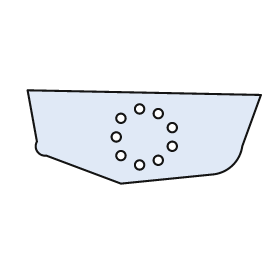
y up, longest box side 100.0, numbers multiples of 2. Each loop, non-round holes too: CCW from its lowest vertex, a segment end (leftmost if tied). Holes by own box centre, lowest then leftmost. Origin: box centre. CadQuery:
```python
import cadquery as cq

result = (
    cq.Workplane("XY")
    .moveTo(-10.0, -20.0)
    .lineTo(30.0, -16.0)
    .threePointArc((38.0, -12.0), (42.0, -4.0))
    .lineTo(50.0, 18.0)
    .lineTo(-50.0, 20.0)
    .lineTo(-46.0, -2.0)
    .threePointArc((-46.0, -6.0), (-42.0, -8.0))
    .close()
    .moveTo(-2.0, -12.0)
    .circle(2.0)
    .moveTo(6.0, -10.0)
    .circle(2.0)
    .moveTo(-10.0, -8.0)
    .circle(2.0)
    .moveTo(12.0, -4.0)
    .circle(2.0)
    .moveTo(-12.0, 0.0)
    .circle(2.0)
    .moveTo(12.0, 4.0)
    .circle(2.0)
    .moveTo(-10.0, 8.0)
    .circle(2.0)
    .moveTo(6.0, 10.0)
    .circle(2.0)
    .moveTo(-2.0, 12.0)
    .circle(2.0)
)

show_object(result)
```